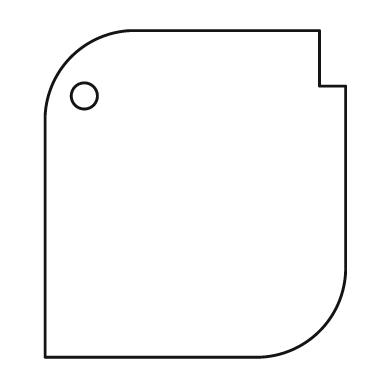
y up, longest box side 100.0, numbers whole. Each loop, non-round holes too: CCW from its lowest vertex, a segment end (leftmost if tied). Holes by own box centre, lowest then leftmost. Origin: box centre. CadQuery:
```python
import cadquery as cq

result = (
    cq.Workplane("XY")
    .moveTo(-46.0, -50.0)
    .lineTo(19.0, -50.0)
    .threePointArc((38.0, -42.0), (46.0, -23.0))
    .lineTo(46.0, 33.0)
    .lineTo(38.0, 33.0)
    .lineTo(38.0, 50.0)
    .lineTo(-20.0, 50.0)
    .threePointArc((-38.0, 42.0), (-46.0, 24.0))
    .close()
    .moveTo(-34.0, 30.0)
    .circle(4.0)
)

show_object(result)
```